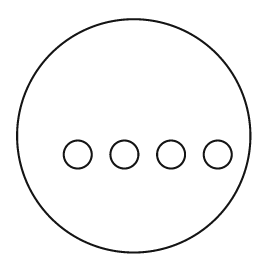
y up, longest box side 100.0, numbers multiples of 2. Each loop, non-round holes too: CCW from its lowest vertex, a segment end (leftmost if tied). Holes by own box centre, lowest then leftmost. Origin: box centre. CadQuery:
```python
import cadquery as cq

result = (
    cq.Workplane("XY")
    .moveTo(0.0, 0.0)
    .circle(50.0)
    .moveTo(-24.0, -8.0)
    .circle(6.0)
    .moveTo(-4.0, -8.0)
    .circle(6.0)
    .moveTo(16.0, -8.0)
    .circle(6.0)
    .moveTo(36.0, -8.0)
    .circle(6.0)
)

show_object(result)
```